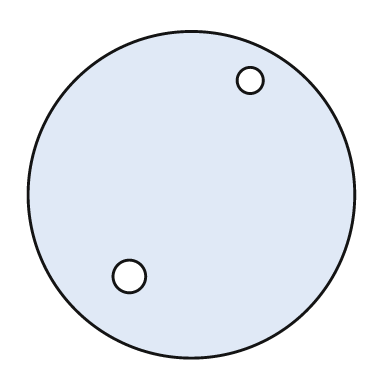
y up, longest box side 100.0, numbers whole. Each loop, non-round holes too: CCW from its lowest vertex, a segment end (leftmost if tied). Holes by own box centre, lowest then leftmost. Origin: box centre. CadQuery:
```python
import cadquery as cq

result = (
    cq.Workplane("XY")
    .moveTo(0.0, 0.0)
    .circle(50.0)
    .moveTo(-19.0, -25.0)
    .circle(5.0)
    .moveTo(18.0, 35.0)
    .circle(4.0)
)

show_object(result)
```